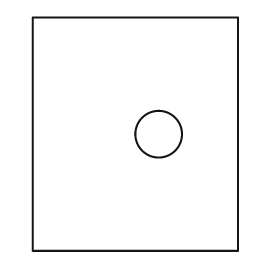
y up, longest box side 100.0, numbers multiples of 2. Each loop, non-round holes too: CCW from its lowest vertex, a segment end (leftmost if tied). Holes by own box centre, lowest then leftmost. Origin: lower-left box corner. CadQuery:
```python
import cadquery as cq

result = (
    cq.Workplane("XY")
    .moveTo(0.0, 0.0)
    .lineTo(88.0, 0.0)
    .lineTo(88.0, 100.0)
    .lineTo(0.0, 100.0)
    .close()
    .moveTo(54.0, 50.0)
    .circle(10.0)
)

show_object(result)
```